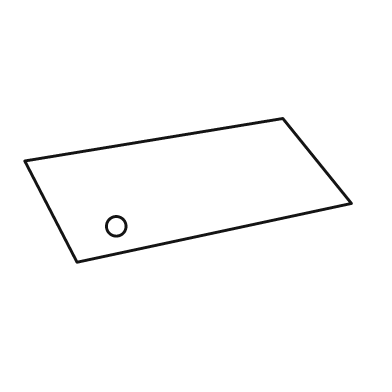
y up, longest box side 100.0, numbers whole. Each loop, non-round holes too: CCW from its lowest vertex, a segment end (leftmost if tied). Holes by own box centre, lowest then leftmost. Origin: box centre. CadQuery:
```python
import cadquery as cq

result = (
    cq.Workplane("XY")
    .moveTo(-34.0, -22.0)
    .lineTo(50.0, -4.0)
    .lineTo(29.0, 22.0)
    .lineTo(-50.0, 9.0)
    .close()
    .moveTo(-22.0, -11.0)
    .circle(3.0)
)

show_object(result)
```